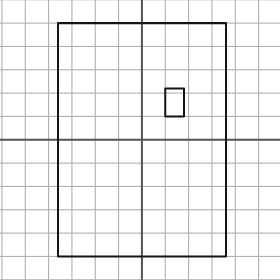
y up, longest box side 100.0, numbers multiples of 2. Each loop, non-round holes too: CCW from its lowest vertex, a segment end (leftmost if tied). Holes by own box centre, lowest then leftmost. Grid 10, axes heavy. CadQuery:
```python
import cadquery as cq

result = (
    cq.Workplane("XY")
    .moveTo(-36.0, -50.0)
    .lineTo(36.0, -50.0)
    .lineTo(36.0, 50.0)
    .lineTo(-36.0, 50.0)
    .close()
    .moveTo(10.0, 10.0)
    .lineTo(18.0, 10.0)
    .lineTo(18.0, 22.0)
    .lineTo(10.0, 22.0)
    .close()
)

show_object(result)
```